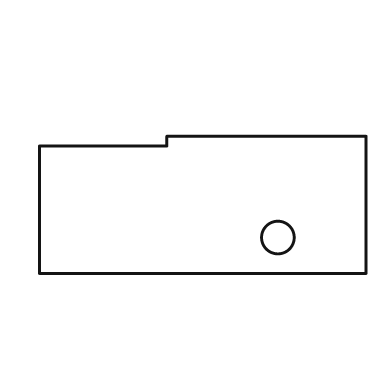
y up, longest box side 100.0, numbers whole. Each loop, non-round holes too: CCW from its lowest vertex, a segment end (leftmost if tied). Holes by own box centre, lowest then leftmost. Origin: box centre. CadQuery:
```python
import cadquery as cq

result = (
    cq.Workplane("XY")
    .moveTo(-50.0, -21.0)
    .lineTo(50.0, -21.0)
    .lineTo(50.0, 21.0)
    .lineTo(-11.0, 21.0)
    .lineTo(-11.0, 18.0)
    .lineTo(-50.0, 18.0)
    .close()
    .moveTo(23.0, -10.0)
    .circle(5.0)
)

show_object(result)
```